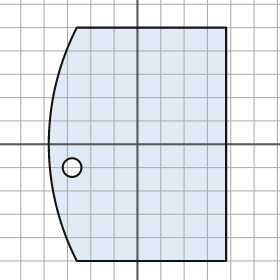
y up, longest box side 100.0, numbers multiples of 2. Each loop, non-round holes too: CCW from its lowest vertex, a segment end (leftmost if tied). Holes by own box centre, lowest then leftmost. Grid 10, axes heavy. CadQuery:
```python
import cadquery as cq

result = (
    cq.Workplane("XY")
    .moveTo(-26.0, -50.0)
    .lineTo(38.0, -50.0)
    .lineTo(38.0, 50.0)
    .lineTo(-26.0, 50.0)
    .threePointArc((-38.0, 0.0), (-26.0, -50.0))
    .close()
    .moveTo(-28.0, -10.0)
    .circle(4.0)
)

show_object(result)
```